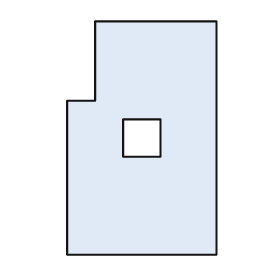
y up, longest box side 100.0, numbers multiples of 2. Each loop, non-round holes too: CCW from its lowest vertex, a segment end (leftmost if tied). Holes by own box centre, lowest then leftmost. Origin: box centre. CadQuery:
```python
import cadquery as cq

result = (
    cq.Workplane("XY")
    .moveTo(-32.0, -50.0)
    .lineTo(32.0, -50.0)
    .lineTo(32.0, 50.0)
    .lineTo(-20.0, 50.0)
    .lineTo(-20.0, 16.0)
    .lineTo(-32.0, 16.0)
    .close()
    .moveTo(-8.0, -8.0)
    .lineTo(8.0, -8.0)
    .lineTo(8.0, 8.0)
    .lineTo(-8.0, 8.0)
    .close()
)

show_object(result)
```